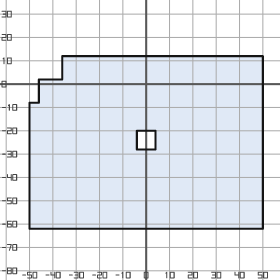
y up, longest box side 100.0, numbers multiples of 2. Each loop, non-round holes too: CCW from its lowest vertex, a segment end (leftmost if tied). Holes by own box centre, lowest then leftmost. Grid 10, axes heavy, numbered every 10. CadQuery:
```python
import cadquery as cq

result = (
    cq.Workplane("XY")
    .moveTo(-50.0, -62.0)
    .lineTo(50.0, -62.0)
    .lineTo(50.0, 12.0)
    .lineTo(-36.0, 12.0)
    .lineTo(-36.0, 2.0)
    .lineTo(-46.0, 2.0)
    .lineTo(-46.0, -8.0)
    .lineTo(-50.0, -8.0)
    .close()
    .moveTo(-4.0, -28.0)
    .lineTo(4.0, -28.0)
    .lineTo(4.0, -20.0)
    .lineTo(-4.0, -20.0)
    .close()
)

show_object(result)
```